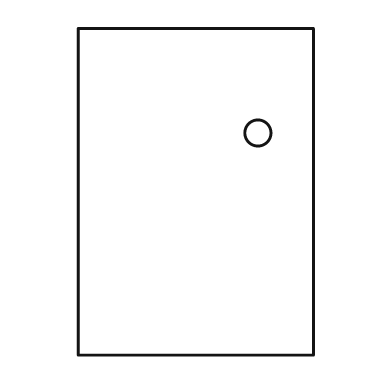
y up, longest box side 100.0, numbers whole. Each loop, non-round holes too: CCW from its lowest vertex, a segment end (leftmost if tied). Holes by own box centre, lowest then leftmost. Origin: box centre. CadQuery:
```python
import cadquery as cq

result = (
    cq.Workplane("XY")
    .moveTo(-36.0, -50.0)
    .lineTo(36.0, -50.0)
    .lineTo(36.0, 50.0)
    .lineTo(-36.0, 50.0)
    .close()
    .moveTo(19.0, 18.0)
    .circle(4.0)
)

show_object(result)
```